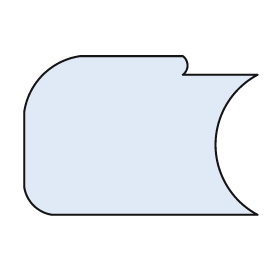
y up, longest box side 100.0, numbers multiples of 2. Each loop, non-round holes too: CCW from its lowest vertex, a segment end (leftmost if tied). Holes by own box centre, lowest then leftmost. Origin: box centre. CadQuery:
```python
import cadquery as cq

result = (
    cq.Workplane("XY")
    .moveTo(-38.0, -34.0)
    .lineTo(50.0, -34.0)
    .threePointArc((32.0, -4.0), (50.0, 26.0))
    .lineTo(18.0, 26.0)
    .threePointArc((20.0, 30.0), (18.0, 34.0))
    .lineTo(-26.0, 34.0)
    .threePointArc((-42.0, 26.0), (-50.0, 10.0))
    .lineTo(-50.0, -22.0)
    .threePointArc((-46.0, -30.0), (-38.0, -34.0))
    .close()
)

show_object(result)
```